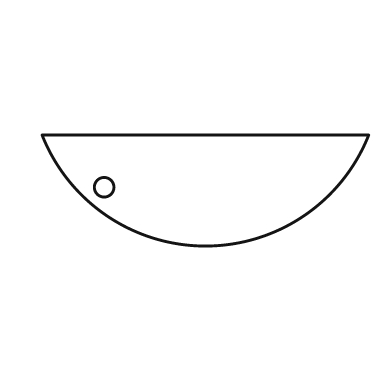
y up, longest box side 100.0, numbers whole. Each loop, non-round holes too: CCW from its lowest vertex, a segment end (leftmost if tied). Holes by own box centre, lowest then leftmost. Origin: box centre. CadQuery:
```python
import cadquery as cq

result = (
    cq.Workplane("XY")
    .moveTo(-50.0, 17.0)
    .threePointArc((0.0, -17.0), (50.0, 17.0))
    .close()
    .moveTo(-31.0, 1.0)
    .circle(3.0)
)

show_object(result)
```